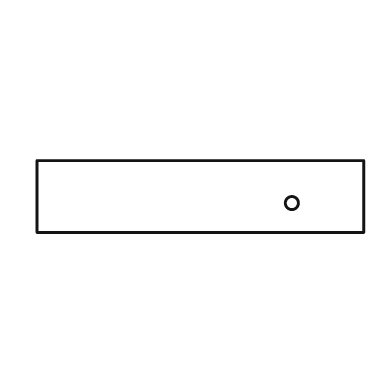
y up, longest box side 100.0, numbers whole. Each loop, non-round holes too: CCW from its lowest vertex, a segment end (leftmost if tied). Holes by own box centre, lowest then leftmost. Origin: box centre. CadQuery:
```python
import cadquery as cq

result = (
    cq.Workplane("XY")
    .moveTo(-50.0, -11.0)
    .lineTo(50.0, -11.0)
    .lineTo(50.0, 11.0)
    .lineTo(-50.0, 11.0)
    .close()
    .moveTo(28.0, -2.0)
    .circle(2.0)
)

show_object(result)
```